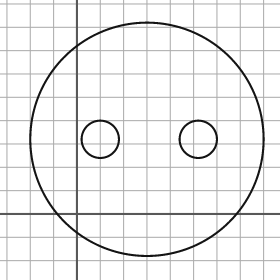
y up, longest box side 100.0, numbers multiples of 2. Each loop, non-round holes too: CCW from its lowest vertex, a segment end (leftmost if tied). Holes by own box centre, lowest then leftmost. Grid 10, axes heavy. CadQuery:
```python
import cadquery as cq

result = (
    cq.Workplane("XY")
    .moveTo(30.0, 32.0)
    .circle(50.0)
    .moveTo(10.0, 32.0)
    .circle(8.0)
    .moveTo(52.0, 32.0)
    .circle(8.0)
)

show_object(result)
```